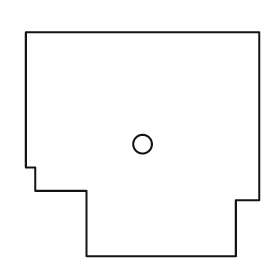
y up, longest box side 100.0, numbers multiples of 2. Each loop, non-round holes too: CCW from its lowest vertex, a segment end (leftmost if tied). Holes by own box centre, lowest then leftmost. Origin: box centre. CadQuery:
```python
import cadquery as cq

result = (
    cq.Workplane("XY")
    .moveTo(-24.0, -48.0)
    .lineTo(40.0, -48.0)
    .lineTo(40.0, -24.0)
    .lineTo(50.0, -24.0)
    .lineTo(50.0, 48.0)
    .lineTo(-50.0, 48.0)
    .lineTo(-50.0, -10.0)
    .lineTo(-46.0, -10.0)
    .lineTo(-46.0, -20.0)
    .lineTo(-24.0, -20.0)
    .close()
    .moveTo(0.0, 0.0)
    .circle(4.0)
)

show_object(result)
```